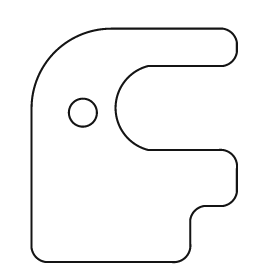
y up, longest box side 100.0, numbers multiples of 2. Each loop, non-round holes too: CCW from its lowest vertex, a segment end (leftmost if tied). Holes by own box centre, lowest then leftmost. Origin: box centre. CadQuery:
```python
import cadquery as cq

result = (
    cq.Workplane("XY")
    .moveTo(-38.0, -50.0)
    .lineTo(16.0, -50.0)
    .threePointArc((22.0, -48.0), (24.0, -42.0))
    .lineTo(24.0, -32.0)
    .threePointArc((26.0, -28.0), (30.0, -26.0))
    .lineTo(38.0, -26.0)
    .threePointArc((42.0, -24.0), (44.0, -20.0))
    .lineTo(44.0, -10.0)
    .threePointArc((42.0, -4.0), (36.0, -2.0))
    .lineTo(6.0, -2.0)
    .threePointArc((-8.0, 16.0), (6.0, 34.0))
    .lineTo(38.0, 34.0)
    .threePointArc((42.0, 36.0), (44.0, 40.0))
    .lineTo(44.0, 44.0)
    .threePointArc((42.0, 48.0), (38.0, 50.0))
    .lineTo(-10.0, 50.0)
    .threePointArc((-34.0, 40.0), (-44.0, 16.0))
    .lineTo(-44.0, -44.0)
    .threePointArc((-42.0, -48.0), (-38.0, -50.0))
    .close()
    .moveTo(-22.0, 14.0)
    .circle(6.0)
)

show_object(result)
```